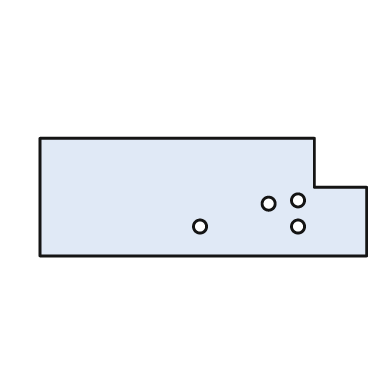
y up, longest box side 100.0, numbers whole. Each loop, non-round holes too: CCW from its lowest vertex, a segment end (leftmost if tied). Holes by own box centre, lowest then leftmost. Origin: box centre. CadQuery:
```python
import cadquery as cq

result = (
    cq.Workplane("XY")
    .moveTo(-50.0, -18.0)
    .lineTo(50.0, -18.0)
    .lineTo(50.0, 3.0)
    .lineTo(34.0, 3.0)
    .lineTo(34.0, 18.0)
    .lineTo(-50.0, 18.0)
    .close()
    .moveTo(-1.0, -9.0)
    .circle(2.0)
    .moveTo(29.0, -9.0)
    .circle(2.0)
    .moveTo(20.0, -2.0)
    .circle(2.0)
    .moveTo(29.0, -1.0)
    .circle(2.0)
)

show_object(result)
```